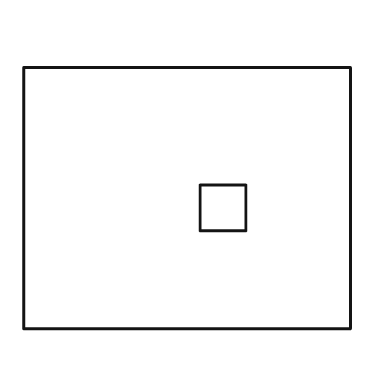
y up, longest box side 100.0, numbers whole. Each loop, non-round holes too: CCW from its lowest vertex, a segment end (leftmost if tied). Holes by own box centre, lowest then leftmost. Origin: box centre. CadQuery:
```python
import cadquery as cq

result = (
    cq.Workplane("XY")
    .moveTo(-50.0, -40.0)
    .lineTo(50.0, -40.0)
    .lineTo(50.0, 40.0)
    .lineTo(-50.0, 40.0)
    .close()
    .moveTo(4.0, -10.0)
    .lineTo(18.0, -10.0)
    .lineTo(18.0, 4.0)
    .lineTo(4.0, 4.0)
    .close()
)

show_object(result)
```